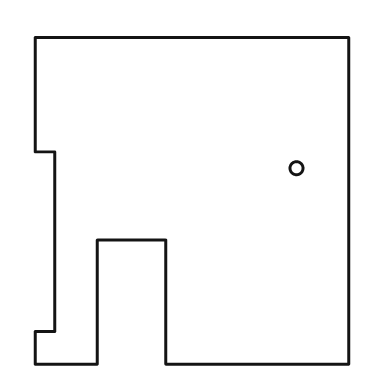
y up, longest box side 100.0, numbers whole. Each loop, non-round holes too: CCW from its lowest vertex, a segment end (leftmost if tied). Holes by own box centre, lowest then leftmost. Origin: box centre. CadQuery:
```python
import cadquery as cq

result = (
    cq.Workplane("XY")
    .moveTo(-48.0, -50.0)
    .lineTo(-29.0, -50.0)
    .lineTo(-29.0, -12.0)
    .lineTo(-8.0, -12.0)
    .lineTo(-8.0, -50.0)
    .lineTo(48.0, -50.0)
    .lineTo(48.0, 50.0)
    .lineTo(-48.0, 50.0)
    .lineTo(-48.0, 15.0)
    .lineTo(-42.0, 15.0)
    .lineTo(-42.0, -40.0)
    .lineTo(-48.0, -40.0)
    .close()
    .moveTo(32.0, 10.0)
    .circle(2.0)
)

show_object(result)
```